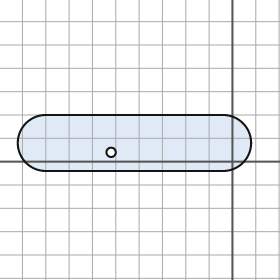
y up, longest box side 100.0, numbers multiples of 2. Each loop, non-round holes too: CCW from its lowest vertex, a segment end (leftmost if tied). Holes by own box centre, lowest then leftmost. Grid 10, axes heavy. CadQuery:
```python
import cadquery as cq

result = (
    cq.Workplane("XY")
    .moveTo(-80.0, -4.0)
    .lineTo(-4.0, -4.0)
    .threePointArc((8.0, 8.0), (-4.0, 20.0))
    .lineTo(-80.0, 20.0)
    .threePointArc((-92.0, 8.0), (-80.0, -4.0))
    .close()
    .moveTo(-52.0, 4.0)
    .circle(2.0)
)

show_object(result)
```